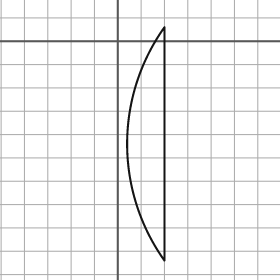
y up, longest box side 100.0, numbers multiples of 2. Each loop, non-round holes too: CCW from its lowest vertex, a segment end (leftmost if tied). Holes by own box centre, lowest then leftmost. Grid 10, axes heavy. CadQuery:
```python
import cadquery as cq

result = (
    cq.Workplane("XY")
    .moveTo(20.0, -94.0)
    .lineTo(20.0, 6.0)
    .threePointArc((4.0, -44.0), (20.0, -94.0))
    .close()
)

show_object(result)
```